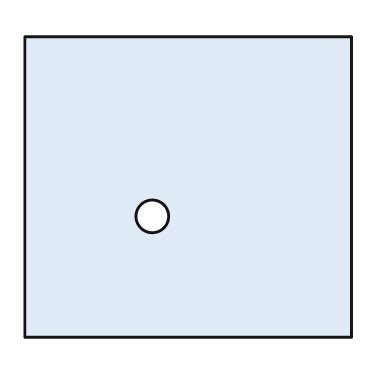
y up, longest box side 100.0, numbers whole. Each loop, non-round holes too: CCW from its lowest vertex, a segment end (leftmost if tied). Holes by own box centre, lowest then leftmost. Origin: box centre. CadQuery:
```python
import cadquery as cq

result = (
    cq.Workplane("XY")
    .moveTo(-50.0, -46.0)
    .lineTo(50.0, -46.0)
    .lineTo(50.0, 46.0)
    .lineTo(-50.0, 46.0)
    .close()
    .moveTo(-11.0, -9.0)
    .circle(5.0)
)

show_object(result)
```